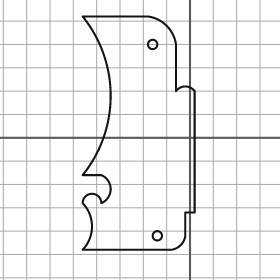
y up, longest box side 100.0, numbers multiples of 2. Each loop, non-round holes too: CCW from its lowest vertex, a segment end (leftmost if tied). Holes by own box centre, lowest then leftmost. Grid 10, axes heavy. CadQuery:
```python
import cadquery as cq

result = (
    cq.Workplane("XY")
    .moveTo(-46.0, -48.0)
    .lineTo(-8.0, -48.0)
    .threePointArc((-4.0, -46.0), (-2.0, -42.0))
    .lineTo(-2.0, -32.0)
    .lineTo(2.0, -32.0)
    .lineTo(2.0, 20.0)
    .threePointArc((-2.0, 22.0), (-6.0, 20.0))
    .lineTo(-6.0, 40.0)
    .threePointArc((-10.0, 48.0), (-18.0, 52.0))
    .lineTo(-46.0, 52.0)
    .threePointArc((-34.0, 18.0), (-46.0, -16.0))
    .lineTo(-38.0, -16.0)
    .threePointArc((-34.0, -22.0), (-38.0, -28.0))
    .threePointArc((-42.0, -24.0), (-46.0, -28.0))
    .threePointArc((-42.0, -38.0), (-46.0, -48.0))
    .close()
    .moveTo(-14.0, -42.0)
    .circle(2.0)
    .moveTo(-16.0, 40.0)
    .circle(2.0)
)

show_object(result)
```